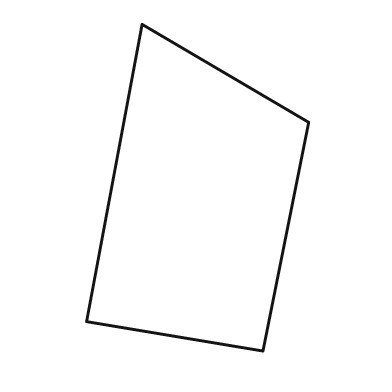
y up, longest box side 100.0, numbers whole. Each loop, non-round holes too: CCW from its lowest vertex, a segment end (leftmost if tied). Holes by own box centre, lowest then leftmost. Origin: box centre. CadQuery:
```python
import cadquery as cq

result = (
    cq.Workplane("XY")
    .moveTo(20.0, -50.0)
    .lineTo(34.0, 20.0)
    .lineTo(-17.0, 50.0)
    .lineTo(-34.0, -41.0)
    .close()
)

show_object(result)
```